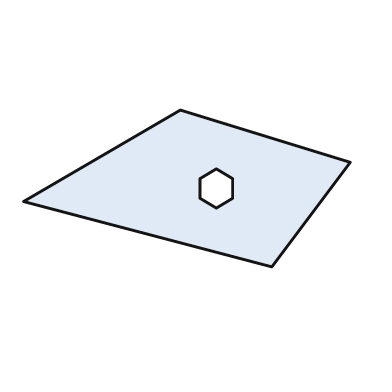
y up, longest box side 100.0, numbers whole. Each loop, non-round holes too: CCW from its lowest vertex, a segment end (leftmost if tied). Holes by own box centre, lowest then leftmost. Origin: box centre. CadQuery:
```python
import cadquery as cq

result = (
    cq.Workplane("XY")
    .moveTo(26.0, -24.0)
    .lineTo(50.0, 8.0)
    .lineTo(-2.0, 24.0)
    .lineTo(-50.0, -4.0)
    .close()
    .moveTo(9.0, -6.0)
    .lineTo(14.0, -3.0)
    .lineTo(14.0, 3.0)
    .lineTo(9.0, 6.0)
    .lineTo(4.0, 3.0)
    .lineTo(4.0, -3.0)
    .close()
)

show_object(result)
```